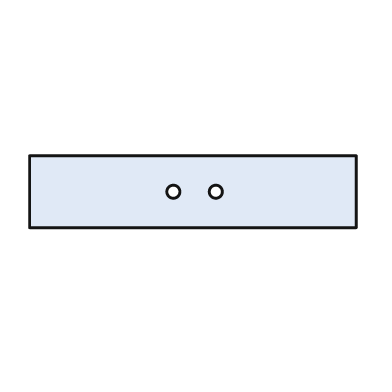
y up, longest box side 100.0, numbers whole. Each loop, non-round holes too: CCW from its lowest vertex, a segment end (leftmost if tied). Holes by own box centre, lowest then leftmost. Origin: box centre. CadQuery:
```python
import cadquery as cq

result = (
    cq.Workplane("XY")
    .moveTo(-50.0, -11.0)
    .lineTo(50.0, -11.0)
    .lineTo(50.0, 11.0)
    .lineTo(-50.0, 11.0)
    .close()
    .moveTo(-6.0, 0.0)
    .circle(2.0)
    .moveTo(7.0, 0.0)
    .circle(2.0)
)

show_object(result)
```